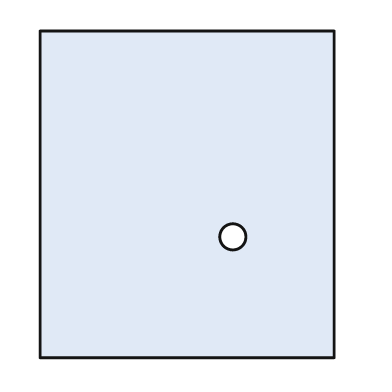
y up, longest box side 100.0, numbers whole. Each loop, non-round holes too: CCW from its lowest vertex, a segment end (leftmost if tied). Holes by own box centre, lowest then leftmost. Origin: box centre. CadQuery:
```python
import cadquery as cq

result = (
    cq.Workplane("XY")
    .moveTo(-45.0, -50.0)
    .lineTo(45.0, -50.0)
    .lineTo(45.0, 50.0)
    .lineTo(-45.0, 50.0)
    .close()
    .moveTo(14.0, -13.0)
    .circle(4.0)
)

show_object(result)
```